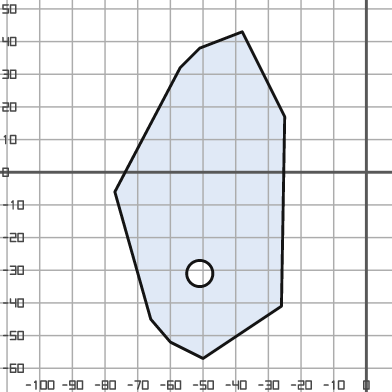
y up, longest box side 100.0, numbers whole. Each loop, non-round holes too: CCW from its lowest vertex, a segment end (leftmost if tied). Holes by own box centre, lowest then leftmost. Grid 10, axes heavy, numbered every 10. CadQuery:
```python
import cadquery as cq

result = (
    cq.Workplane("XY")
    .moveTo(-50.0, -57.0)
    .lineTo(-26.0, -41.0)
    .lineTo(-25.0, 17.0)
    .lineTo(-38.0, 43.0)
    .lineTo(-51.0, 38.0)
    .lineTo(-57.0, 32.0)
    .lineTo(-77.0, -6.0)
    .lineTo(-66.0, -45.0)
    .lineTo(-60.0, -52.0)
    .close()
    .moveTo(-51.0, -31.0)
    .circle(4.0)
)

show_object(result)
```